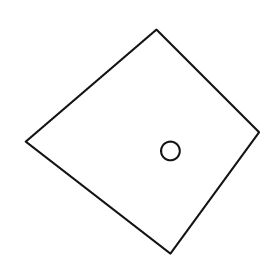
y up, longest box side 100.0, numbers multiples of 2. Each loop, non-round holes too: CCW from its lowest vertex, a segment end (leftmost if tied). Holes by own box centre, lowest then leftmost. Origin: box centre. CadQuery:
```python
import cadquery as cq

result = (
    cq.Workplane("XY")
    .moveTo(12.0, -48.0)
    .lineTo(50.0, 4.0)
    .lineTo(6.0, 48.0)
    .lineTo(-50.0, 0.0)
    .close()
    .moveTo(12.0, -4.0)
    .circle(4.0)
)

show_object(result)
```